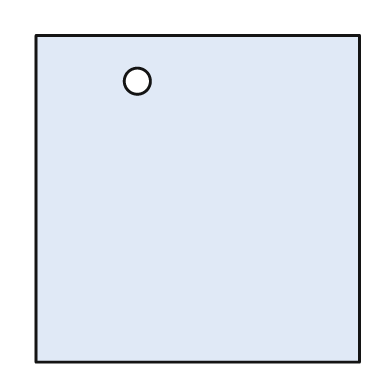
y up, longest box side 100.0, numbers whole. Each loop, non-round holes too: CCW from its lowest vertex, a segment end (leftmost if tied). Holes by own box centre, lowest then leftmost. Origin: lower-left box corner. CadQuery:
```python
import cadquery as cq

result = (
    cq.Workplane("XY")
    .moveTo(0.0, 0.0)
    .lineTo(99.0, 0.0)
    .lineTo(99.0, 100.0)
    .lineTo(0.0, 100.0)
    .close()
    .moveTo(31.0, 86.0)
    .circle(4.0)
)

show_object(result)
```